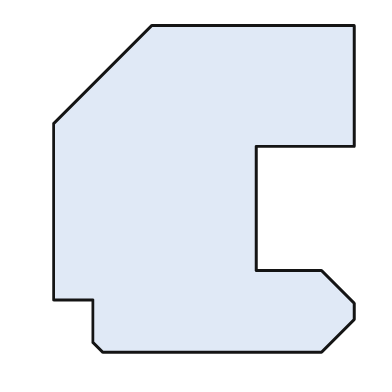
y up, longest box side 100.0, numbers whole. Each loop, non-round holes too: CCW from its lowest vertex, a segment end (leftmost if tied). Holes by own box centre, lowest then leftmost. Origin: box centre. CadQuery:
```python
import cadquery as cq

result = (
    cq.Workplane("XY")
    .moveTo(-31.0, -50.0)
    .lineTo(36.0, -50.0)
    .lineTo(46.0, -40.0)
    .lineTo(46.0, -35.0)
    .lineTo(36.0, -25.0)
    .lineTo(16.0, -25.0)
    .lineTo(16.0, 13.0)
    .lineTo(46.0, 13.0)
    .lineTo(46.0, 50.0)
    .lineTo(-16.0, 50.0)
    .lineTo(-46.0, 20.0)
    .lineTo(-46.0, -34.0)
    .lineTo(-34.0, -34.0)
    .lineTo(-34.0, -47.0)
    .close()
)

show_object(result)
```